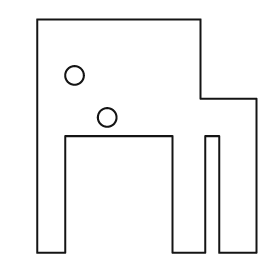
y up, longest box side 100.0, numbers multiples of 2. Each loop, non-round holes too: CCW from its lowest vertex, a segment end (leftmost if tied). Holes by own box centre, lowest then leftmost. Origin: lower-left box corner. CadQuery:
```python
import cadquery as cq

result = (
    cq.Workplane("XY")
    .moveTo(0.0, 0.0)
    .lineTo(12.0, 0.0)
    .lineTo(12.0, 50.0)
    .lineTo(58.0, 50.0)
    .lineTo(58.0, 0.0)
    .lineTo(72.0, 0.0)
    .lineTo(72.0, 50.0)
    .lineTo(78.0, 50.0)
    .lineTo(78.0, 0.0)
    .lineTo(94.0, 0.0)
    .lineTo(94.0, 66.0)
    .lineTo(70.0, 66.0)
    .lineTo(70.0, 100.0)
    .lineTo(0.0, 100.0)
    .close()
    .moveTo(30.0, 58.0)
    .circle(4.0)
    .moveTo(16.0, 76.0)
    .circle(4.0)
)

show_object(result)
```